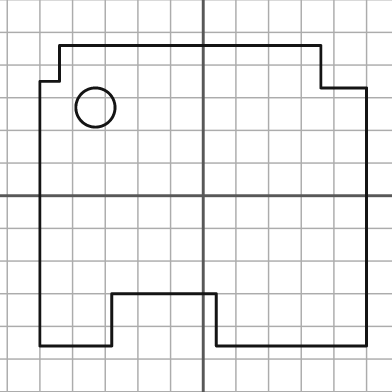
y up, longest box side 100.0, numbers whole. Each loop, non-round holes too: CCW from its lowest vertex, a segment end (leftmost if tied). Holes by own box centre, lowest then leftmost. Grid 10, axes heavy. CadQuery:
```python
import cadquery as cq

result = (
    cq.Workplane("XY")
    .moveTo(-50.0, -46.0)
    .lineTo(-28.0, -46.0)
    .lineTo(-28.0, -30.0)
    .lineTo(4.0, -30.0)
    .lineTo(4.0, -46.0)
    .lineTo(50.0, -46.0)
    .lineTo(50.0, 33.0)
    .lineTo(36.0, 33.0)
    .lineTo(36.0, 46.0)
    .lineTo(-44.0, 46.0)
    .lineTo(-44.0, 35.0)
    .lineTo(-50.0, 35.0)
    .close()
    .moveTo(-33.0, 27.0)
    .circle(6.0)
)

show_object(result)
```